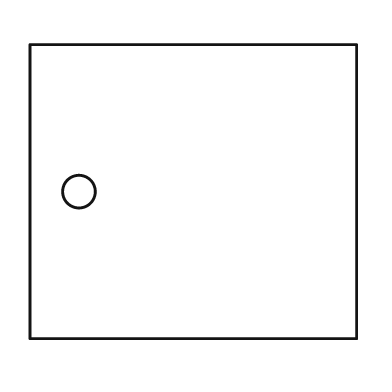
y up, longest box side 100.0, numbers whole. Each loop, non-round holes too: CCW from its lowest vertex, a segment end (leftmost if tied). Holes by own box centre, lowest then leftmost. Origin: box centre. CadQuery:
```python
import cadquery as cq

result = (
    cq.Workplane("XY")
    .moveTo(-50.0, -45.0)
    .lineTo(50.0, -45.0)
    .lineTo(50.0, 45.0)
    .lineTo(-50.0, 45.0)
    .close()
    .moveTo(-35.0, 0.0)
    .circle(5.0)
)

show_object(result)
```